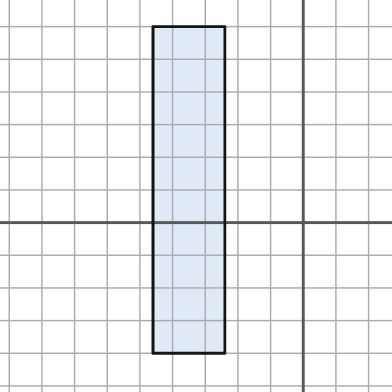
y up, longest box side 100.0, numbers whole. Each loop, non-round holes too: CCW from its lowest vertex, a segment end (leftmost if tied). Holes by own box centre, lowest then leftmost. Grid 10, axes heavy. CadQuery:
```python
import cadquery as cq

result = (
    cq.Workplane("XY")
    .moveTo(-46.0, -40.0)
    .lineTo(-24.0, -40.0)
    .lineTo(-24.0, 60.0)
    .lineTo(-46.0, 60.0)
    .close()
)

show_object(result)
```